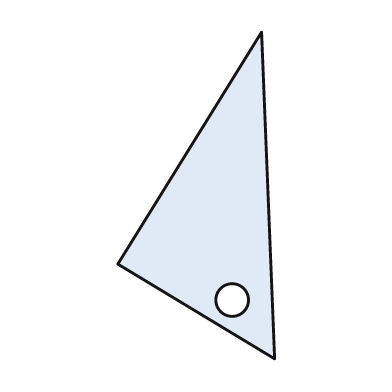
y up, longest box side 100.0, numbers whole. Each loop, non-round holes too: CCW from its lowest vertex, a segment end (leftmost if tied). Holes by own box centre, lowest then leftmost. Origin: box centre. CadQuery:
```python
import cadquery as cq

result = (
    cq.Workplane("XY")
    .moveTo(24.0, -50.0)
    .lineTo(20.0, 50.0)
    .lineTo(-24.0, -21.0)
    .close()
    .moveTo(11.0, -32.0)
    .circle(5.0)
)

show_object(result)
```